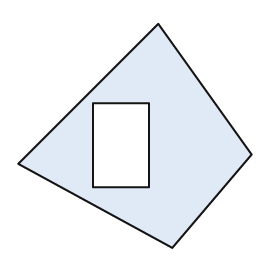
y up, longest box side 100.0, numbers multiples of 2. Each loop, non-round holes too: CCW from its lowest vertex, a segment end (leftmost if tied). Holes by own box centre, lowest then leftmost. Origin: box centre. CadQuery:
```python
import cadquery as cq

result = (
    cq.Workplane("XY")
    .moveTo(16.0, -48.0)
    .lineTo(50.0, -8.0)
    .lineTo(10.0, 48.0)
    .lineTo(-50.0, -12.0)
    .close()
    .moveTo(-18.0, -22.0)
    .lineTo(6.0, -22.0)
    .lineTo(6.0, 14.0)
    .lineTo(-18.0, 14.0)
    .close()
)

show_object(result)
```